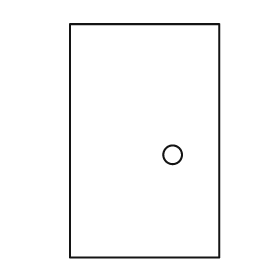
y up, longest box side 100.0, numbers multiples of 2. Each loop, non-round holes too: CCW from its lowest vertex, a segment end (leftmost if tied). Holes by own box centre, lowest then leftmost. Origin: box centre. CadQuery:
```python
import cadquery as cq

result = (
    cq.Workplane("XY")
    .moveTo(-32.0, -50.0)
    .lineTo(32.0, -50.0)
    .lineTo(32.0, 50.0)
    .lineTo(-32.0, 50.0)
    .close()
    .moveTo(12.0, -6.0)
    .circle(4.0)
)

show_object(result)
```